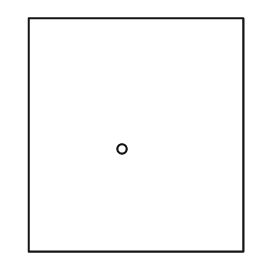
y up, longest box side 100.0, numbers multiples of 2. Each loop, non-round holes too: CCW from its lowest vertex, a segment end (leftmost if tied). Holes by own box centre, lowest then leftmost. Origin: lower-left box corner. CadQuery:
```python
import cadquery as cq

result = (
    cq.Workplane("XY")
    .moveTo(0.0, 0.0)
    .lineTo(92.0, 0.0)
    .lineTo(92.0, 100.0)
    .lineTo(0.0, 100.0)
    .close()
    .moveTo(40.0, 44.0)
    .circle(2.0)
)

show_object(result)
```